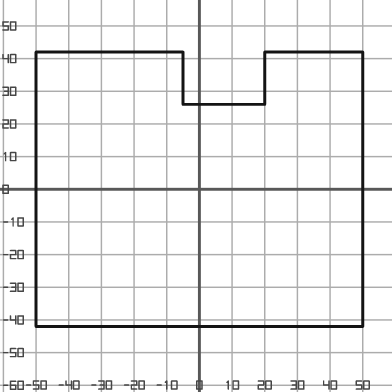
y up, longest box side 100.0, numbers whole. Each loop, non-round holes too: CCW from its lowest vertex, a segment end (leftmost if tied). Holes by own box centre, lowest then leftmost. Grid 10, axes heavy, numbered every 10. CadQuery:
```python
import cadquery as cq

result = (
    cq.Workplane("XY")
    .moveTo(-50.0, -42.0)
    .lineTo(50.0, -42.0)
    .lineTo(50.0, 42.0)
    .lineTo(20.0, 42.0)
    .lineTo(20.0, 26.0)
    .lineTo(-5.0, 26.0)
    .lineTo(-5.0, 42.0)
    .lineTo(-50.0, 42.0)
    .close()
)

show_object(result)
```